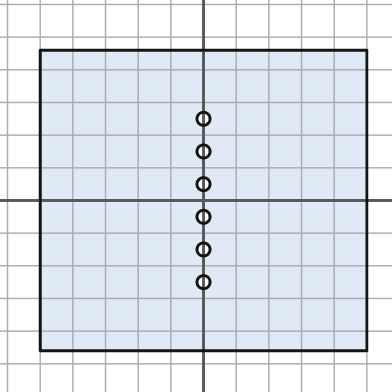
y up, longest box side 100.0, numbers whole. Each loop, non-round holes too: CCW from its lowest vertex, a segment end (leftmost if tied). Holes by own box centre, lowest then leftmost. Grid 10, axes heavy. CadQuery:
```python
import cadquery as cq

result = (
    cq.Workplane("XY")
    .moveTo(-50.0, -46.0)
    .lineTo(50.0, -46.0)
    .lineTo(50.0, 46.0)
    .lineTo(-50.0, 46.0)
    .close()
    .moveTo(0.0, -25.0)
    .circle(2.0)
    .moveTo(0.0, -15.0)
    .circle(2.0)
    .moveTo(0.0, -5.0)
    .circle(2.0)
    .moveTo(0.0, 5.0)
    .circle(2.0)
    .moveTo(0.0, 15.0)
    .circle(2.0)
    .moveTo(0.0, 25.0)
    .circle(2.0)
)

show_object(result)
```